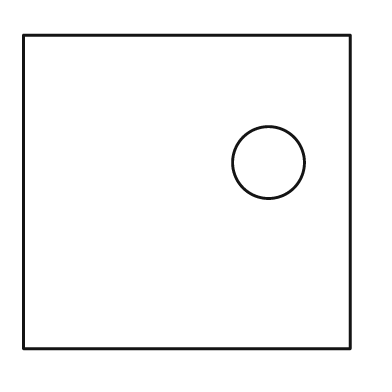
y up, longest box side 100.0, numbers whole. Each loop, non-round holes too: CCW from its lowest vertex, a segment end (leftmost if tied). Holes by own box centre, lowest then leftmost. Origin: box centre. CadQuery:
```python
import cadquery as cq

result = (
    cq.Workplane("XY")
    .moveTo(-50.0, -48.0)
    .lineTo(50.0, -48.0)
    .lineTo(50.0, 48.0)
    .lineTo(-50.0, 48.0)
    .close()
    .moveTo(25.0, 9.0)
    .circle(11.0)
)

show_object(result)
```